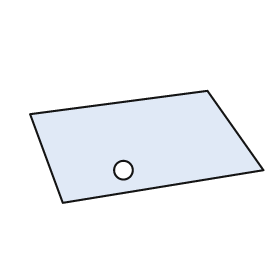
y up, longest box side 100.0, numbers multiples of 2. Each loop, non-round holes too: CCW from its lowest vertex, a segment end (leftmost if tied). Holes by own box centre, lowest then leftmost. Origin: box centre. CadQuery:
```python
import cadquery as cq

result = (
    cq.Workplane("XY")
    .moveTo(-36.0, -24.0)
    .lineTo(50.0, -10.0)
    .lineTo(26.0, 24.0)
    .lineTo(-50.0, 14.0)
    .close()
    .moveTo(-10.0, -10.0)
    .circle(4.0)
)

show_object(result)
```